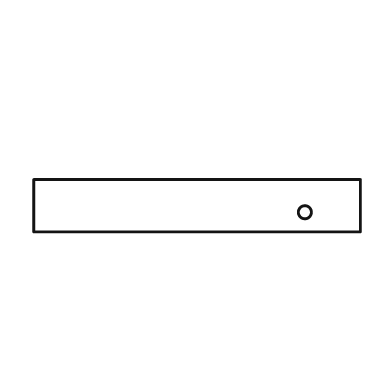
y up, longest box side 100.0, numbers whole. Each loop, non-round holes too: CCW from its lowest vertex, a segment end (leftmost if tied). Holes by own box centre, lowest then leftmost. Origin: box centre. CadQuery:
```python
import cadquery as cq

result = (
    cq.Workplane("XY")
    .moveTo(-50.0, -8.0)
    .lineTo(50.0, -8.0)
    .lineTo(50.0, 8.0)
    .lineTo(-50.0, 8.0)
    .close()
    .moveTo(33.0, -2.0)
    .circle(2.0)
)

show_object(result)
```